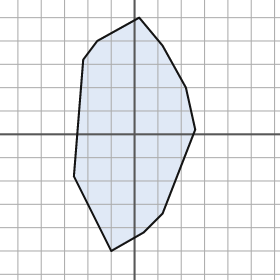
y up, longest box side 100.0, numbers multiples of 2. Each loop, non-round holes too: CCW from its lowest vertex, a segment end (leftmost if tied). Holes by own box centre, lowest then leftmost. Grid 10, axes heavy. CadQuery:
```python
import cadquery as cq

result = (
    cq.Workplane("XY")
    .moveTo(-10.0, -50.0)
    .lineTo(4.0, -42.0)
    .lineTo(12.0, -34.0)
    .lineTo(26.0, 2.0)
    .lineTo(22.0, 20.0)
    .lineTo(12.0, 38.0)
    .lineTo(2.0, 50.0)
    .lineTo(-16.0, 40.0)
    .lineTo(-22.0, 32.0)
    .lineTo(-26.0, -18.0)
    .close()
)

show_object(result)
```